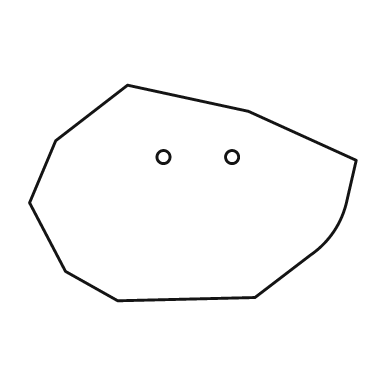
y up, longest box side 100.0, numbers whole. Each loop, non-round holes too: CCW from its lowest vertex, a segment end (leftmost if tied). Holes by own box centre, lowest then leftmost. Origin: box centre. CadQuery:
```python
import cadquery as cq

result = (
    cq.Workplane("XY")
    .moveTo(-23.0, -33.0)
    .lineTo(19.0, -32.0)
    .lineTo(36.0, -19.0)
    .threePointArc((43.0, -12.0), (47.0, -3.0))
    .lineTo(50.0, 10.0)
    .lineTo(17.0, 25.0)
    .lineTo(-20.0, 33.0)
    .lineTo(-42.0, 16.0)
    .lineTo(-50.0, -3.0)
    .lineTo(-39.0, -24.0)
    .close()
    .moveTo(-9.0, 11.0)
    .circle(2.0)
    .moveTo(12.0, 11.0)
    .circle(2.0)
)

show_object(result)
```